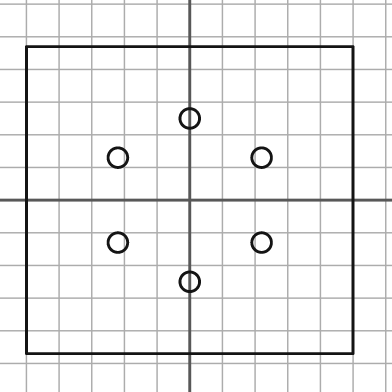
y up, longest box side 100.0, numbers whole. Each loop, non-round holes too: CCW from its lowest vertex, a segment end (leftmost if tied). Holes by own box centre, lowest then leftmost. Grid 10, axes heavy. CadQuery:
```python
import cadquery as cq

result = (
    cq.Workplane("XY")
    .moveTo(-50.0, -47.0)
    .lineTo(50.0, -47.0)
    .lineTo(50.0, 47.0)
    .lineTo(-50.0, 47.0)
    .close()
    .moveTo(0.0, -25.0)
    .circle(3.0)
    .moveTo(-22.0, -13.0)
    .circle(3.0)
    .moveTo(22.0, -13.0)
    .circle(3.0)
    .moveTo(-22.0, 13.0)
    .circle(3.0)
    .moveTo(22.0, 13.0)
    .circle(3.0)
    .moveTo(0.0, 25.0)
    .circle(3.0)
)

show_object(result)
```